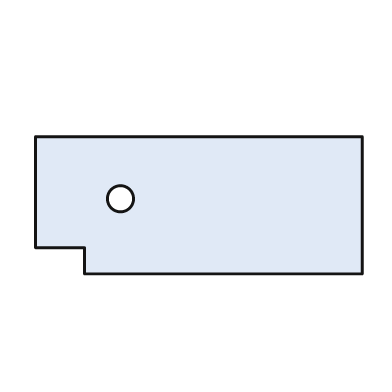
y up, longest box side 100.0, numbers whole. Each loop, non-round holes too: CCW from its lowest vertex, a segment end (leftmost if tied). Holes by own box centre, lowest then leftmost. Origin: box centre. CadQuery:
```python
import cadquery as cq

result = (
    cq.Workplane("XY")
    .moveTo(-35.0, -21.0)
    .lineTo(50.0, -21.0)
    .lineTo(50.0, 21.0)
    .lineTo(-50.0, 21.0)
    .lineTo(-50.0, -13.0)
    .lineTo(-35.0, -13.0)
    .close()
    .moveTo(-24.0, 2.0)
    .circle(4.0)
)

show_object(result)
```